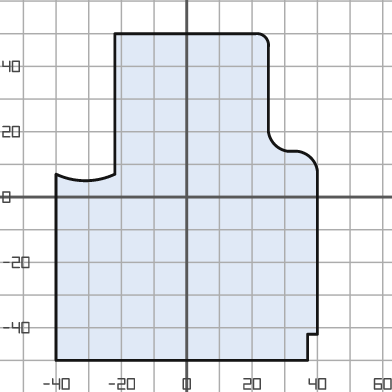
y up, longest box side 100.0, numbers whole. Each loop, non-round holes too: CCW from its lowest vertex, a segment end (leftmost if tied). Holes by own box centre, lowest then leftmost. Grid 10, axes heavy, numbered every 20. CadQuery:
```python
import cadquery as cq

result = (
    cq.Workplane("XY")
    .moveTo(-40.0, -50.0)
    .lineTo(37.0, -50.0)
    .lineTo(37.0, -42.0)
    .lineTo(40.0, -42.0)
    .lineTo(40.0, 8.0)
    .threePointArc((38.0, 12.0), (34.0, 14.0))
    .lineTo(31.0, 14.0)
    .threePointArc((27.0, 16.0), (25.0, 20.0))
    .lineTo(25.0, 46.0)
    .threePointArc((24.0, 49.0), (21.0, 50.0))
    .lineTo(-22.0, 50.0)
    .lineTo(-22.0, 7.0)
    .threePointArc((-31.0, 5.0), (-40.0, 7.0))
    .close()
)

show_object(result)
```